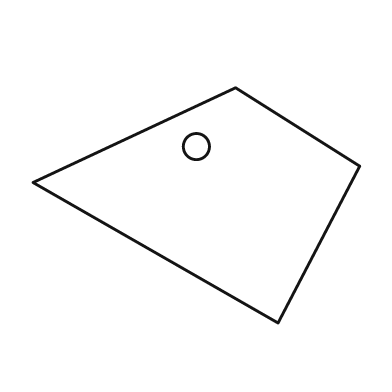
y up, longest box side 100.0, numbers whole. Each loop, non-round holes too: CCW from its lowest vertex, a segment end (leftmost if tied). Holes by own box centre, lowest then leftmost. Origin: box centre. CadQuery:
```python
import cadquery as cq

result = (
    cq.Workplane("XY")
    .moveTo(25.0, -36.0)
    .lineTo(50.0, 12.0)
    .lineTo(12.0, 36.0)
    .lineTo(-50.0, 7.0)
    .close()
    .moveTo(0.0, 18.0)
    .circle(4.0)
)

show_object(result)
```